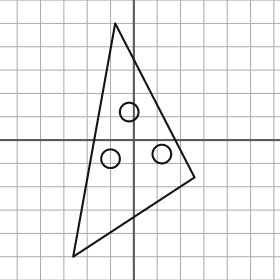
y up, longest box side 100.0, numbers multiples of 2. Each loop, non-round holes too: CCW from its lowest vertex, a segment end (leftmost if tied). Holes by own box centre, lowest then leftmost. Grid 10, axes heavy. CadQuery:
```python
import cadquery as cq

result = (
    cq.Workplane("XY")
    .moveTo(-26.0, -50.0)
    .lineTo(26.0, -16.0)
    .lineTo(-8.0, 50.0)
    .close()
    .moveTo(-10.0, -8.0)
    .circle(4.0)
    .moveTo(12.0, -6.0)
    .circle(4.0)
    .moveTo(-2.0, 12.0)
    .circle(4.0)
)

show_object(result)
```